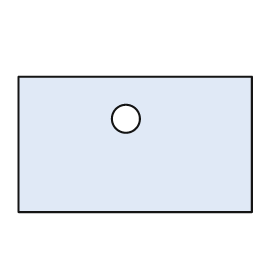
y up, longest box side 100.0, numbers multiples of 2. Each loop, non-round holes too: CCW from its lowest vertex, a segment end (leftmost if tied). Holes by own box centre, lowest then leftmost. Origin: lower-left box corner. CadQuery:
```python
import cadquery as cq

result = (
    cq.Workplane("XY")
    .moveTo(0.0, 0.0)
    .lineTo(100.0, 0.0)
    .lineTo(100.0, 58.0)
    .lineTo(0.0, 58.0)
    .close()
    .moveTo(46.0, 40.0)
    .circle(6.0)
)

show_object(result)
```